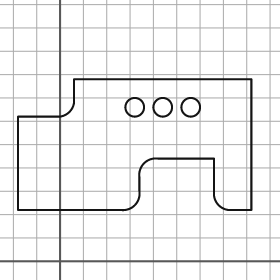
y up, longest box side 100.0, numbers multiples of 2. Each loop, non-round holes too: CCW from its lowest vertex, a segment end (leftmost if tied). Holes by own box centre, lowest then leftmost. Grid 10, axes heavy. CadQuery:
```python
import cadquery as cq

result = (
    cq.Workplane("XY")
    .moveTo(-18.0, 22.0)
    .lineTo(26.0, 22.0)
    .threePointArc((32.0, 24.0), (34.0, 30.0))
    .lineTo(34.0, 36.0)
    .threePointArc((36.0, 42.0), (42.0, 44.0))
    .lineTo(66.0, 44.0)
    .lineTo(66.0, 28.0)
    .threePointArc((68.0, 24.0), (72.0, 22.0))
    .lineTo(82.0, 22.0)
    .lineTo(82.0, 78.0)
    .lineTo(6.0, 78.0)
    .lineTo(6.0, 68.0)
    .threePointArc((4.0, 64.0), (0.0, 62.0))
    .lineTo(-18.0, 62.0)
    .close()
    .moveTo(32.0, 66.0)
    .circle(4.0)
    .moveTo(44.0, 66.0)
    .circle(4.0)
    .moveTo(56.0, 66.0)
    .circle(4.0)
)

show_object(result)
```